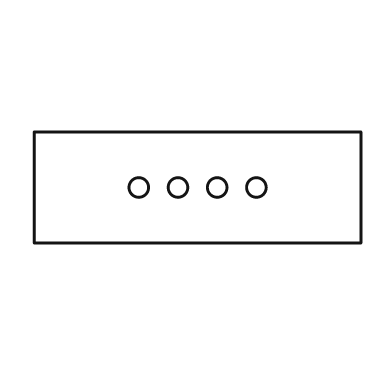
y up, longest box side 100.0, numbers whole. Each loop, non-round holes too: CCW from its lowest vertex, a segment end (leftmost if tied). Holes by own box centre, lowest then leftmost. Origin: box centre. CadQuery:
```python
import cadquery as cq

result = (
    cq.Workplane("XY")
    .moveTo(-50.0, -17.0)
    .lineTo(50.0, -17.0)
    .lineTo(50.0, 17.0)
    .lineTo(-50.0, 17.0)
    .close()
    .moveTo(-18.0, 0.0)
    .circle(3.0)
    .moveTo(-6.0, 0.0)
    .circle(3.0)
    .moveTo(6.0, 0.0)
    .circle(3.0)
    .moveTo(18.0, 0.0)
    .circle(3.0)
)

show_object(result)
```